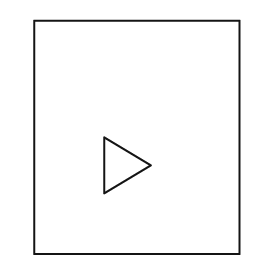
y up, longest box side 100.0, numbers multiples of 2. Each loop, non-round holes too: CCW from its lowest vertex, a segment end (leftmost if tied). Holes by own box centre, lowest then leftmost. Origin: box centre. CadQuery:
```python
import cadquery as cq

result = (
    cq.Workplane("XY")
    .moveTo(-44.0, -50.0)
    .lineTo(44.0, -50.0)
    .lineTo(44.0, 50.0)
    .lineTo(-44.0, 50.0)
    .close()
    .moveTo(-14.0, -24.0)
    .lineTo(6.0, -12.0)
    .lineTo(-14.0, 0.0)
    .close()
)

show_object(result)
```